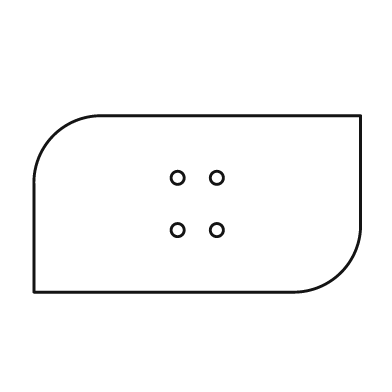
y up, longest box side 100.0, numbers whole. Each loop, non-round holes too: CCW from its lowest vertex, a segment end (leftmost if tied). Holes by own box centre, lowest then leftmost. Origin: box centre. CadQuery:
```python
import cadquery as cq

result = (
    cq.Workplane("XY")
    .moveTo(-50.0, -27.0)
    .lineTo(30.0, -27.0)
    .threePointArc((44.0, -21.0), (50.0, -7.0))
    .lineTo(50.0, 27.0)
    .lineTo(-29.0, 27.0)
    .threePointArc((-44.0, 21.0), (-50.0, 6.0))
    .close()
    .moveTo(-6.0, -8.0)
    .circle(2.0)
    .moveTo(6.0, -8.0)
    .circle(2.0)
    .moveTo(-6.0, 8.0)
    .circle(2.0)
    .moveTo(6.0, 8.0)
    .circle(2.0)
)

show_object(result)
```